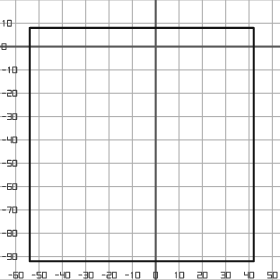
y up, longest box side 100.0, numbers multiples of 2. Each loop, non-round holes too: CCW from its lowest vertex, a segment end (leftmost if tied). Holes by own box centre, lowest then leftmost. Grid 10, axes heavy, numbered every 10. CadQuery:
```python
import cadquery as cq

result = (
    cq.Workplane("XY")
    .moveTo(-54.0, -92.0)
    .lineTo(42.0, -92.0)
    .lineTo(42.0, 8.0)
    .lineTo(-54.0, 8.0)
    .close()
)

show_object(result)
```